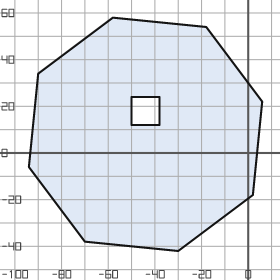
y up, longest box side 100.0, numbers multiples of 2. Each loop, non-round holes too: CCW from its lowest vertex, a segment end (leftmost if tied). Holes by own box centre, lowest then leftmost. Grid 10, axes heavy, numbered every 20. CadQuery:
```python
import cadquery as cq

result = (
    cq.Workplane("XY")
    .moveTo(-30.0, -42.0)
    .lineTo(2.0, -18.0)
    .lineTo(6.0, 22.0)
    .lineTo(-18.0, 54.0)
    .lineTo(-58.0, 58.0)
    .lineTo(-90.0, 34.0)
    .lineTo(-94.0, -6.0)
    .lineTo(-70.0, -38.0)
    .close()
    .moveTo(-50.0, 12.0)
    .lineTo(-38.0, 12.0)
    .lineTo(-38.0, 24.0)
    .lineTo(-50.0, 24.0)
    .close()
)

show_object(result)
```